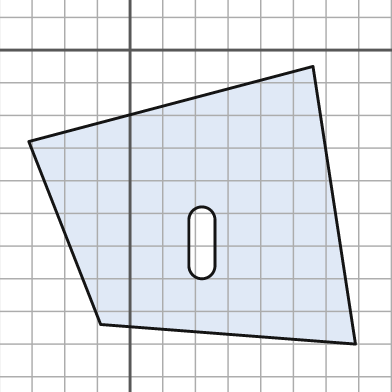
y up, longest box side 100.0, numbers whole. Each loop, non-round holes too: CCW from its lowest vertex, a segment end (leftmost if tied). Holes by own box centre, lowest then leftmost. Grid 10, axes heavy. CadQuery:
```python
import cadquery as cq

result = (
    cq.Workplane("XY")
    .moveTo(69.0, -90.0)
    .lineTo(56.0, -5.0)
    .lineTo(-31.0, -28.0)
    .lineTo(-9.0, -84.0)
    .close()
    .moveTo(18.0, -66.0)
    .threePointArc((22.0, -70.0), (26.0, -66.0))
    .lineTo(26.0, -52.0)
    .threePointArc((22.0, -48.0), (18.0, -52.0))
    .close()
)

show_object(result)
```